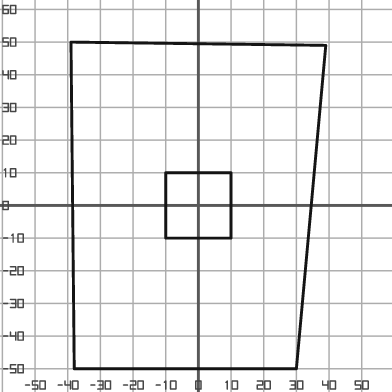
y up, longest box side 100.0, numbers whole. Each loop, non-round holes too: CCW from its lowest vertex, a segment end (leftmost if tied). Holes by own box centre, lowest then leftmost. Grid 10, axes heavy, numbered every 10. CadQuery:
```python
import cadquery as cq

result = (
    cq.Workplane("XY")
    .moveTo(-38.0, -50.0)
    .lineTo(30.0, -50.0)
    .lineTo(39.0, 49.0)
    .lineTo(-39.0, 50.0)
    .close()
    .moveTo(-10.0, -10.0)
    .lineTo(10.0, -10.0)
    .lineTo(10.0, 10.0)
    .lineTo(-10.0, 10.0)
    .close()
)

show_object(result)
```